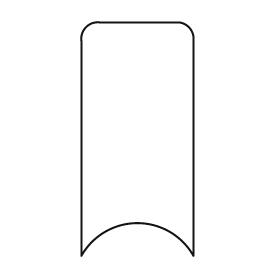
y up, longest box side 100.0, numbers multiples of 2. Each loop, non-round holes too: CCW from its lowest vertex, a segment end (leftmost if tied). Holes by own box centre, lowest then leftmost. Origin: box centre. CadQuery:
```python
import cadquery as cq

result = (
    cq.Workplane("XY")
    .moveTo(-24.0, -50.0)
    .threePointArc((0.0, -36.0), (24.0, -50.0))
    .lineTo(24.0, 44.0)
    .threePointArc((22.0, 48.0), (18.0, 50.0))
    .lineTo(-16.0, 50.0)
    .threePointArc((-22.0, 48.0), (-24.0, 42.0))
    .close()
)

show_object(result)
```